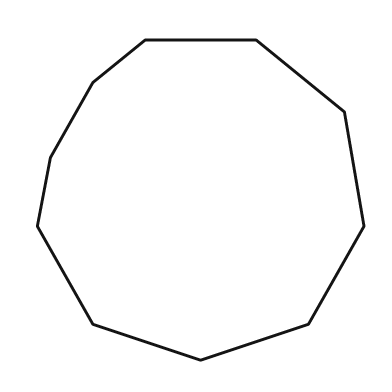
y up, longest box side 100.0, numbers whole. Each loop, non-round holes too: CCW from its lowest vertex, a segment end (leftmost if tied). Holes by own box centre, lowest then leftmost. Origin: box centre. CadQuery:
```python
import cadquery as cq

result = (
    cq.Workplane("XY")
    .moveTo(0.0, -49.0)
    .lineTo(33.0, -38.0)
    .lineTo(50.0, -8.0)
    .lineTo(44.0, 27.0)
    .lineTo(17.0, 49.0)
    .lineTo(-17.0, 49.0)
    .lineTo(-33.0, 36.0)
    .lineTo(-46.0, 13.0)
    .lineTo(-50.0, -8.0)
    .lineTo(-33.0, -38.0)
    .close()
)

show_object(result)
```